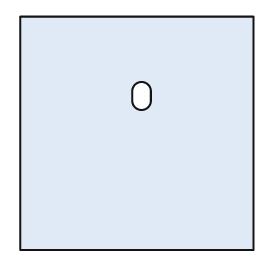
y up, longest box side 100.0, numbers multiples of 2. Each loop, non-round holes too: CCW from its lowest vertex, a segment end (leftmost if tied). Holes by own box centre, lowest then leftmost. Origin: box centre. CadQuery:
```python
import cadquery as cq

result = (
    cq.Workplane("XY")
    .moveTo(-50.0, -50.0)
    .lineTo(50.0, -50.0)
    .lineTo(50.0, 50.0)
    .lineTo(-50.0, 50.0)
    .close()
    .moveTo(-2.0, 14.0)
    .threePointArc((2.0, 10.0), (6.0, 14.0))
    .lineTo(6.0, 18.0)
    .threePointArc((2.0, 22.0), (-2.0, 18.0))
    .close()
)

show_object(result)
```